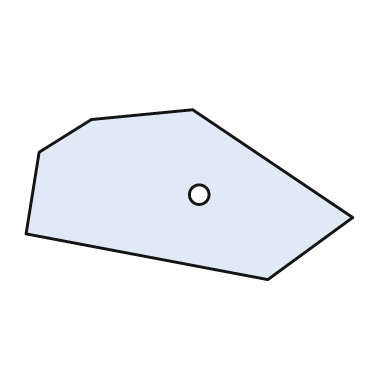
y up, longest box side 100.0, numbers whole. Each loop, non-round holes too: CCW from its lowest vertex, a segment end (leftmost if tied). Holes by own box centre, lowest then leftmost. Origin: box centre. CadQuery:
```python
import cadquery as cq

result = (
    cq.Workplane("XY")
    .moveTo(24.0, -26.0)
    .lineTo(50.0, -7.0)
    .lineTo(1.0, 26.0)
    .lineTo(-30.0, 23.0)
    .lineTo(-46.0, 13.0)
    .lineTo(-50.0, -12.0)
    .close()
    .moveTo(3.0, 0.0)
    .circle(3.0)
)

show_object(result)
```